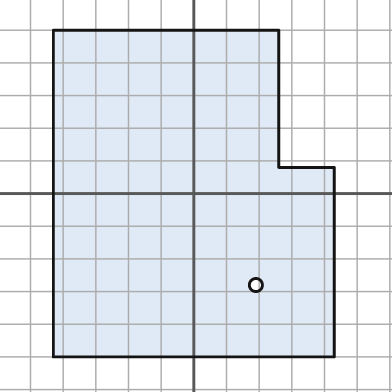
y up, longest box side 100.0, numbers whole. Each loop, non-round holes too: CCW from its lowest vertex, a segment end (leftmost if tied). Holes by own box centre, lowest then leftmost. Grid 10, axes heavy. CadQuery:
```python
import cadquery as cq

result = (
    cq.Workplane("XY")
    .moveTo(-43.0, -50.0)
    .lineTo(43.0, -50.0)
    .lineTo(43.0, 8.0)
    .lineTo(26.0, 8.0)
    .lineTo(26.0, 50.0)
    .lineTo(-43.0, 50.0)
    .close()
    .moveTo(19.0, -28.0)
    .circle(2.0)
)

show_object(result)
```